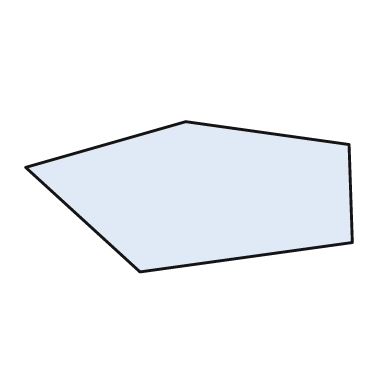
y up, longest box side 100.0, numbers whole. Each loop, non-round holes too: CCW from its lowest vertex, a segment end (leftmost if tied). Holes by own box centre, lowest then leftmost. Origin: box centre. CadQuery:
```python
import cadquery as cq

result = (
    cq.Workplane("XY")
    .moveTo(-15.0, -23.0)
    .lineTo(50.0, -14.0)
    .lineTo(49.0, 16.0)
    .lineTo(-1.0, 23.0)
    .lineTo(-50.0, 9.0)
    .close()
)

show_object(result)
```